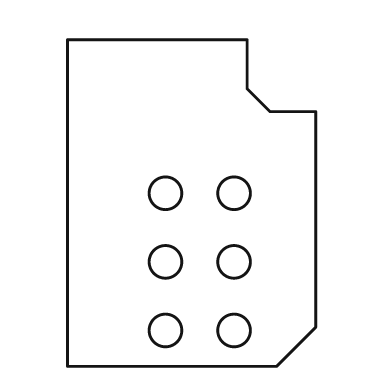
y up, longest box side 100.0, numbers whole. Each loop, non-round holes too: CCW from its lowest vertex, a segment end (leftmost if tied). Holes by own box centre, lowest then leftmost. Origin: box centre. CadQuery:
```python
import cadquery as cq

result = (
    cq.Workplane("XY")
    .moveTo(-38.0, -50.0)
    .lineTo(26.0, -50.0)
    .lineTo(38.0, -38.0)
    .lineTo(38.0, 28.0)
    .lineTo(24.0, 28.0)
    .lineTo(17.0, 35.0)
    .lineTo(17.0, 50.0)
    .lineTo(-38.0, 50.0)
    .close()
    .moveTo(-8.0, -39.0)
    .circle(5.0)
    .moveTo(13.0, -39.0)
    .circle(5.0)
    .moveTo(-8.0, -18.0)
    .circle(5.0)
    .moveTo(13.0, -18.0)
    .circle(5.0)
    .moveTo(-8.0, 3.0)
    .circle(5.0)
    .moveTo(13.0, 3.0)
    .circle(5.0)
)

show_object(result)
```